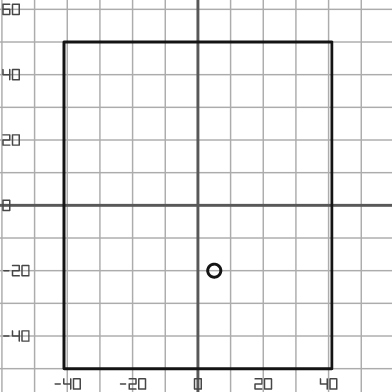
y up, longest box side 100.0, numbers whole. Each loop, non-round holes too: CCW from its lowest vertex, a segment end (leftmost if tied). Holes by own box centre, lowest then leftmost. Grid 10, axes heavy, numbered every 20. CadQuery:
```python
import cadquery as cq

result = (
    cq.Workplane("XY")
    .moveTo(-41.0, -50.0)
    .lineTo(41.0, -50.0)
    .lineTo(41.0, 50.0)
    .lineTo(-41.0, 50.0)
    .close()
    .moveTo(5.0, -20.0)
    .circle(2.0)
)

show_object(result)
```